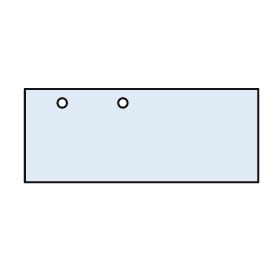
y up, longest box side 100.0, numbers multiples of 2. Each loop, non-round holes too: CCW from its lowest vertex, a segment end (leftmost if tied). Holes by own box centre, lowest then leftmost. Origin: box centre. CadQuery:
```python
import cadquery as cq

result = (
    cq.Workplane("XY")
    .moveTo(-50.0, -20.0)
    .lineTo(50.0, -20.0)
    .lineTo(50.0, 20.0)
    .lineTo(-50.0, 20.0)
    .close()
    .moveTo(-34.0, 14.0)
    .circle(2.0)
    .moveTo(-8.0, 14.0)
    .circle(2.0)
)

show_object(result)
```